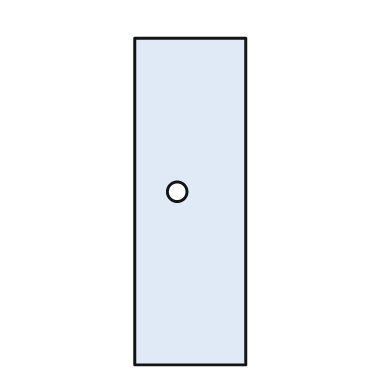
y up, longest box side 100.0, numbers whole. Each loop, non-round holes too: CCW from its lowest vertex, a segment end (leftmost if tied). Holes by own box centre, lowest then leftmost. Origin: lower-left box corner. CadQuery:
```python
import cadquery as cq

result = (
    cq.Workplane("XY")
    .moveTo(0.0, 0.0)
    .lineTo(34.0, 0.0)
    .lineTo(34.0, 100.0)
    .lineTo(0.0, 100.0)
    .close()
    .moveTo(13.0, 53.0)
    .circle(3.0)
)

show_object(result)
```